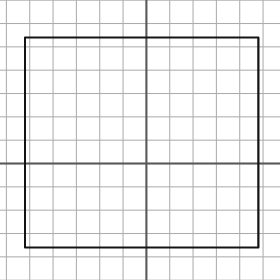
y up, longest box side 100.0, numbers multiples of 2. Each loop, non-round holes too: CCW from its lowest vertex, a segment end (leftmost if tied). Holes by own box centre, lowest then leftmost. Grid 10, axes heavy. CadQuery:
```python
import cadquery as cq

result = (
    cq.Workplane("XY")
    .moveTo(-52.0, -36.0)
    .lineTo(48.0, -36.0)
    .lineTo(48.0, 54.0)
    .lineTo(-52.0, 54.0)
    .close()
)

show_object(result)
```